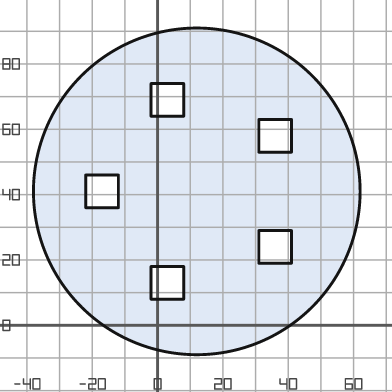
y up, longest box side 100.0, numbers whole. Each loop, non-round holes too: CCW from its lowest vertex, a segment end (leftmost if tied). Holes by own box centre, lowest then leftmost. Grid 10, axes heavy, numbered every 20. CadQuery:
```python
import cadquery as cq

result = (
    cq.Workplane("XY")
    .moveTo(12.0, 41.0)
    .circle(50.0)
    .moveTo(-2.0, 8.0)
    .lineTo(8.0, 8.0)
    .lineTo(8.0, 18.0)
    .lineTo(-2.0, 18.0)
    .close()
    .moveTo(31.0, 19.0)
    .lineTo(41.0, 19.0)
    .lineTo(41.0, 29.0)
    .lineTo(31.0, 29.0)
    .close()
    .moveTo(-22.0, 36.0)
    .lineTo(-12.0, 36.0)
    .lineTo(-12.0, 46.0)
    .lineTo(-22.0, 46.0)
    .close()
    .moveTo(31.0, 53.0)
    .lineTo(41.0, 53.0)
    .lineTo(41.0, 63.0)
    .lineTo(31.0, 63.0)
    .close()
    .moveTo(-2.0, 64.0)
    .lineTo(8.0, 64.0)
    .lineTo(8.0, 74.0)
    .lineTo(-2.0, 74.0)
    .close()
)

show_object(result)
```